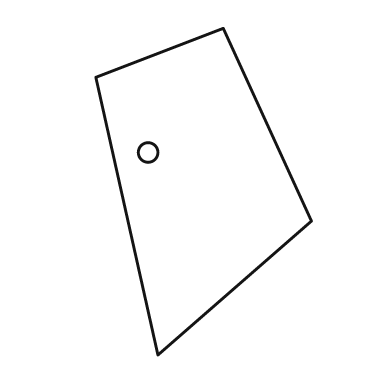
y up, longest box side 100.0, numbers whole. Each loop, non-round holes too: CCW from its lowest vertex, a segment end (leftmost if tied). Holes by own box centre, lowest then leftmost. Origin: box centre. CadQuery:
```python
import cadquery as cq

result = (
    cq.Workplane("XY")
    .moveTo(-14.0, -50.0)
    .lineTo(33.0, -9.0)
    .lineTo(6.0, 50.0)
    .lineTo(-33.0, 35.0)
    .close()
    .moveTo(-17.0, 12.0)
    .circle(3.0)
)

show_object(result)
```